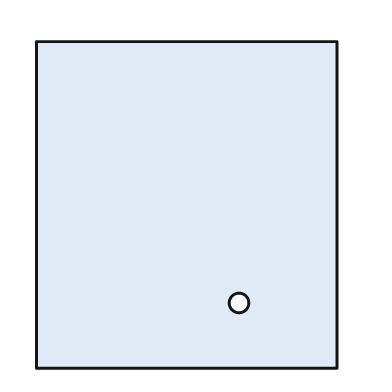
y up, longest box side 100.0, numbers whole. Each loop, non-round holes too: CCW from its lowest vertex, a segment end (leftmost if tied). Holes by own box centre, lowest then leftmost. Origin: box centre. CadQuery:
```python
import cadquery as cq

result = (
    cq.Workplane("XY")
    .moveTo(-46.0, -50.0)
    .lineTo(46.0, -50.0)
    .lineTo(46.0, 50.0)
    .lineTo(-46.0, 50.0)
    .close()
    .moveTo(16.0, -30.0)
    .circle(3.0)
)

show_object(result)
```